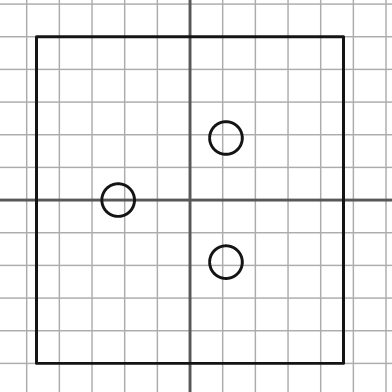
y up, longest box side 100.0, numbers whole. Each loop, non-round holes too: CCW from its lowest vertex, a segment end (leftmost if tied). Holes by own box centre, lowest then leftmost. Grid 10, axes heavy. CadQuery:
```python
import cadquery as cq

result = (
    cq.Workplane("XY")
    .moveTo(-47.0, -50.0)
    .lineTo(47.0, -50.0)
    .lineTo(47.0, 50.0)
    .lineTo(-47.0, 50.0)
    .close()
    .moveTo(11.0, -19.0)
    .circle(5.0)
    .moveTo(-22.0, 0.0)
    .circle(5.0)
    .moveTo(11.0, 19.0)
    .circle(5.0)
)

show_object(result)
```